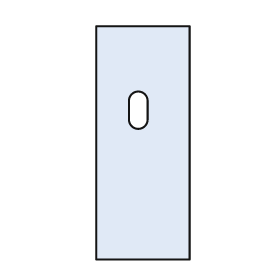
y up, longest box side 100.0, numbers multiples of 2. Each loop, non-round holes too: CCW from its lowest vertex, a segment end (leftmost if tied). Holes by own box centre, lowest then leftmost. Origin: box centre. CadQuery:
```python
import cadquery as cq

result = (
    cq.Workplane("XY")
    .moveTo(-20.0, -50.0)
    .lineTo(20.0, -50.0)
    .lineTo(20.0, 50.0)
    .lineTo(-20.0, 50.0)
    .close()
    .moveTo(-6.0, 10.0)
    .threePointArc((-2.0, 6.0), (2.0, 10.0))
    .lineTo(2.0, 18.0)
    .threePointArc((-2.0, 22.0), (-6.0, 18.0))
    .close()
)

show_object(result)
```